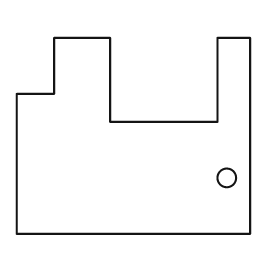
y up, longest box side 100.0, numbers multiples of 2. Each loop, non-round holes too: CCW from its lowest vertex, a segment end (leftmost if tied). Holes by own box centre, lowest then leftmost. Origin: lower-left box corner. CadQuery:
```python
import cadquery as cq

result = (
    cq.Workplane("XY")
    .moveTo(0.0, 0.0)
    .lineTo(100.0, 0.0)
    .lineTo(100.0, 84.0)
    .lineTo(86.0, 84.0)
    .lineTo(86.0, 48.0)
    .lineTo(40.0, 48.0)
    .lineTo(40.0, 84.0)
    .lineTo(16.0, 84.0)
    .lineTo(16.0, 60.0)
    .lineTo(0.0, 60.0)
    .close()
    .moveTo(90.0, 24.0)
    .circle(4.0)
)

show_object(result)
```